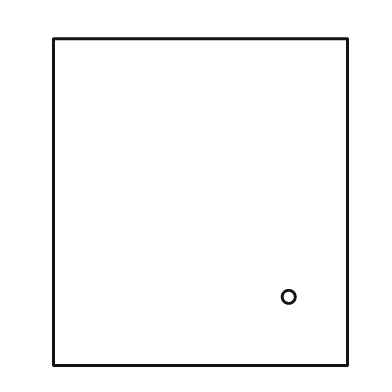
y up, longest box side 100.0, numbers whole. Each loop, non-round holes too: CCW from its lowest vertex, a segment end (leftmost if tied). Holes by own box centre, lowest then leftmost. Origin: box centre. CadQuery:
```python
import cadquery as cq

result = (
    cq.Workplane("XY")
    .moveTo(-45.0, -50.0)
    .lineTo(45.0, -50.0)
    .lineTo(45.0, 50.0)
    .lineTo(-45.0, 50.0)
    .close()
    .moveTo(27.0, -29.0)
    .circle(2.0)
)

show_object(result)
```